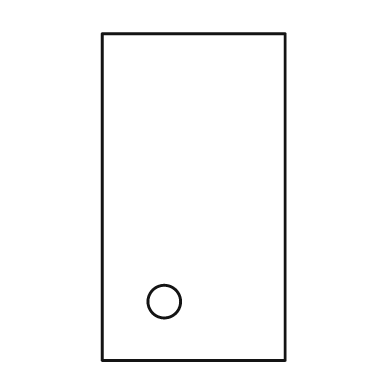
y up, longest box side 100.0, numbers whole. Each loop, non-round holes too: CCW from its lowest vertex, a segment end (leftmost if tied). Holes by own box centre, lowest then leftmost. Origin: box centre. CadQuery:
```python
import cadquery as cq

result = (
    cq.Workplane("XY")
    .moveTo(-28.0, -50.0)
    .lineTo(28.0, -50.0)
    .lineTo(28.0, 50.0)
    .lineTo(-28.0, 50.0)
    .close()
    .moveTo(-9.0, -32.0)
    .circle(5.0)
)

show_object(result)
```